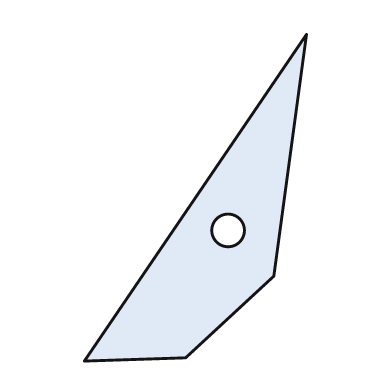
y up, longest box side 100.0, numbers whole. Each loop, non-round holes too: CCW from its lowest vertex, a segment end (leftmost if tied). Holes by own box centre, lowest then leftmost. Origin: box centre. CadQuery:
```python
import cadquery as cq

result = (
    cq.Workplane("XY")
    .moveTo(-34.0, -50.0)
    .lineTo(-3.0, -49.0)
    .lineTo(24.0, -24.0)
    .lineTo(34.0, 50.0)
    .close()
    .moveTo(10.0, -10.0)
    .circle(5.0)
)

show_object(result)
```